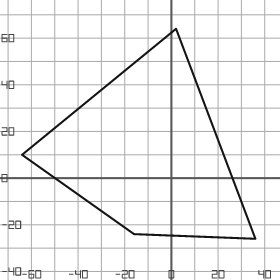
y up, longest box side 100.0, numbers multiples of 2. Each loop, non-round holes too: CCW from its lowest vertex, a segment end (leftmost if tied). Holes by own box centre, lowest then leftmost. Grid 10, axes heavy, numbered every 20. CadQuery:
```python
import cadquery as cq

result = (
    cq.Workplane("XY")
    .moveTo(36.0, -26.0)
    .lineTo(2.0, 64.0)
    .lineTo(-64.0, 10.0)
    .lineTo(-16.0, -24.0)
    .close()
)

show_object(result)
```